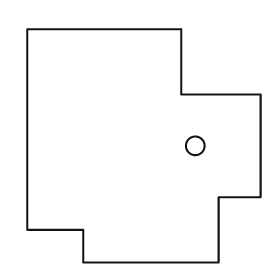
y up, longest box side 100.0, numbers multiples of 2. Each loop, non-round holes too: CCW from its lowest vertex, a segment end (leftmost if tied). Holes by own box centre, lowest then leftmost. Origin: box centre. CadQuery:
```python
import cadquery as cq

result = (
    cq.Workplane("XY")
    .moveTo(-26.0, -50.0)
    .lineTo(32.0, -50.0)
    .lineTo(32.0, -22.0)
    .lineTo(50.0, -22.0)
    .lineTo(50.0, 22.0)
    .lineTo(16.0, 22.0)
    .lineTo(16.0, 50.0)
    .lineTo(-50.0, 50.0)
    .lineTo(-50.0, -36.0)
    .lineTo(-26.0, -36.0)
    .close()
    .moveTo(22.0, 0.0)
    .circle(4.0)
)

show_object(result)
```